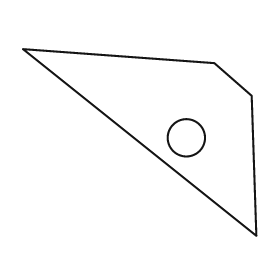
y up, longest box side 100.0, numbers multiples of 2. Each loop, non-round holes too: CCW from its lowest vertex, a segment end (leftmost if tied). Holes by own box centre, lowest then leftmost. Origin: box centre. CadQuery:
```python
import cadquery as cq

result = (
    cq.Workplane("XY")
    .moveTo(50.0, -40.0)
    .lineTo(48.0, 20.0)
    .lineTo(32.0, 34.0)
    .lineTo(-50.0, 40.0)
    .close()
    .moveTo(20.0, 2.0)
    .circle(8.0)
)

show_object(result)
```